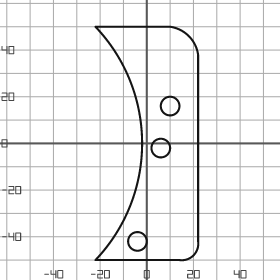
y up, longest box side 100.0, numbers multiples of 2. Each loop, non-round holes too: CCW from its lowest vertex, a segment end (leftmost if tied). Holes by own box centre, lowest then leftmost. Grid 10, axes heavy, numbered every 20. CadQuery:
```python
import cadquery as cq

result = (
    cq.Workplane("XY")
    .moveTo(-22.0, -50.0)
    .lineTo(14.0, -50.0)
    .threePointArc((20.0, -48.0), (22.0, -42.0))
    .lineTo(22.0, 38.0)
    .threePointArc((18.0, 46.0), (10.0, 50.0))
    .lineTo(-22.0, 50.0)
    .threePointArc((-2.0, 0.0), (-22.0, -50.0))
    .close()
    .moveTo(-4.0, -42.0)
    .circle(4.0)
    .moveTo(6.0, -2.0)
    .circle(4.0)
    .moveTo(10.0, 16.0)
    .circle(4.0)
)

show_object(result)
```